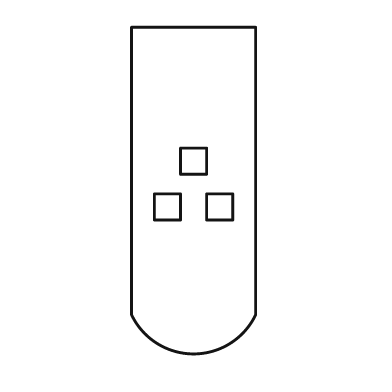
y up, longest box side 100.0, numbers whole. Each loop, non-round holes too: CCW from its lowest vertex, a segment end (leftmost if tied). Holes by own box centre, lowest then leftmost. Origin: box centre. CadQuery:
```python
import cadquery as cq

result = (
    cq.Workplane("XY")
    .moveTo(-19.0, -38.0)
    .threePointArc((0.0, -50.0), (19.0, -38.0))
    .lineTo(19.0, 50.0)
    .lineTo(-19.0, 50.0)
    .close()
    .moveTo(-12.0, -9.0)
    .lineTo(-4.0, -9.0)
    .lineTo(-4.0, -1.0)
    .lineTo(-12.0, -1.0)
    .close()
    .moveTo(4.0, -9.0)
    .lineTo(12.0, -9.0)
    .lineTo(12.0, -1.0)
    .lineTo(4.0, -1.0)
    .close()
    .moveTo(-4.0, 5.0)
    .lineTo(4.0, 5.0)
    .lineTo(4.0, 13.0)
    .lineTo(-4.0, 13.0)
    .close()
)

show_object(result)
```